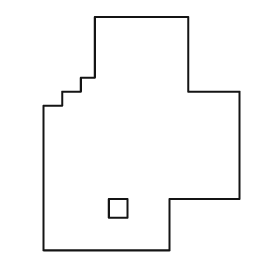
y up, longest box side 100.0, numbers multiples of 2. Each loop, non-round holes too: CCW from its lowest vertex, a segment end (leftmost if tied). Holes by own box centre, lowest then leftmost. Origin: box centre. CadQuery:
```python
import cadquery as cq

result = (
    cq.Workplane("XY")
    .moveTo(-42.0, -50.0)
    .lineTo(12.0, -50.0)
    .lineTo(12.0, -28.0)
    .lineTo(42.0, -28.0)
    .lineTo(42.0, 18.0)
    .lineTo(20.0, 18.0)
    .lineTo(20.0, 50.0)
    .lineTo(-20.0, 50.0)
    .lineTo(-20.0, 24.0)
    .lineTo(-26.0, 24.0)
    .lineTo(-26.0, 18.0)
    .lineTo(-34.0, 18.0)
    .lineTo(-34.0, 12.0)
    .lineTo(-42.0, 12.0)
    .close()
    .moveTo(-14.0, -36.0)
    .lineTo(-6.0, -36.0)
    .lineTo(-6.0, -28.0)
    .lineTo(-14.0, -28.0)
    .close()
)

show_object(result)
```